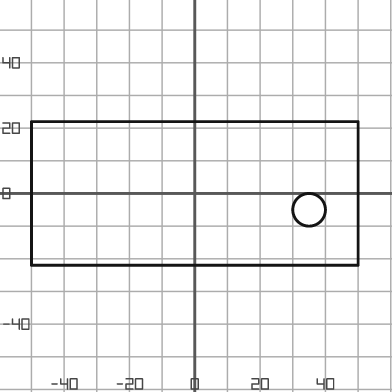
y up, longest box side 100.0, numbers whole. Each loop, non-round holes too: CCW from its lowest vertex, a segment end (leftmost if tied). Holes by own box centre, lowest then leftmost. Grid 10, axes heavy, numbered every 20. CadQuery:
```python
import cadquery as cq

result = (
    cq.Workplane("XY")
    .moveTo(-50.0, -22.0)
    .lineTo(50.0, -22.0)
    .lineTo(50.0, 22.0)
    .lineTo(-50.0, 22.0)
    .close()
    .moveTo(35.0, -5.0)
    .circle(5.0)
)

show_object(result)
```